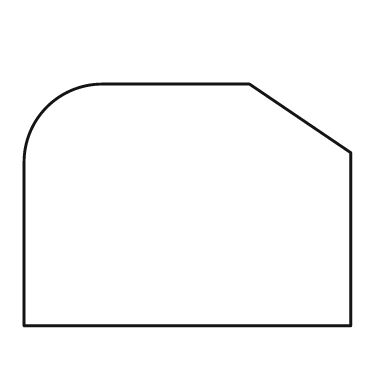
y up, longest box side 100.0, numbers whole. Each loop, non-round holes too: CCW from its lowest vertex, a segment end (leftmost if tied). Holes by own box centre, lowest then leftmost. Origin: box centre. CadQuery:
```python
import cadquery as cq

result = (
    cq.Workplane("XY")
    .moveTo(-50.0, -37.0)
    .lineTo(50.0, -37.0)
    .lineTo(50.0, 16.0)
    .lineTo(19.0, 37.0)
    .lineTo(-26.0, 37.0)
    .threePointArc((-43.0, 30.0), (-50.0, 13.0))
    .close()
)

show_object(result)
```